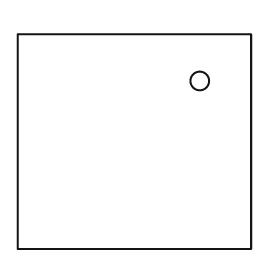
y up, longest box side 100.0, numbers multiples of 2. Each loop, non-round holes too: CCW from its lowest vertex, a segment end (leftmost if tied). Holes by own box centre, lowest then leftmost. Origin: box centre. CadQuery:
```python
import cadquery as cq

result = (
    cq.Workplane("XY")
    .moveTo(-50.0, -46.0)
    .lineTo(50.0, -46.0)
    .lineTo(50.0, 46.0)
    .lineTo(-50.0, 46.0)
    .close()
    .moveTo(28.0, 26.0)
    .circle(4.0)
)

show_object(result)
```